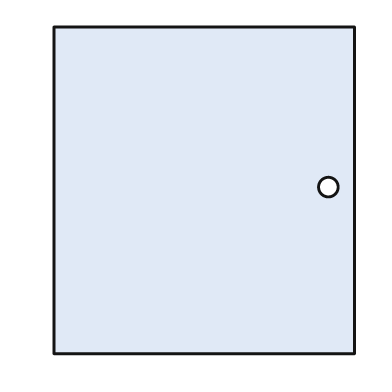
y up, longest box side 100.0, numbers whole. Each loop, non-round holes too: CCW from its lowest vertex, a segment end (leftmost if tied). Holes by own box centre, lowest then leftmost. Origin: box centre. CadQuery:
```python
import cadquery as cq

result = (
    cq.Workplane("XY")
    .moveTo(-46.0, -50.0)
    .lineTo(46.0, -50.0)
    .lineTo(46.0, 50.0)
    .lineTo(-46.0, 50.0)
    .close()
    .moveTo(38.0, 1.0)
    .circle(3.0)
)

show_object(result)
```